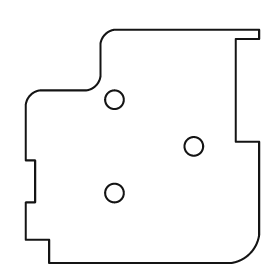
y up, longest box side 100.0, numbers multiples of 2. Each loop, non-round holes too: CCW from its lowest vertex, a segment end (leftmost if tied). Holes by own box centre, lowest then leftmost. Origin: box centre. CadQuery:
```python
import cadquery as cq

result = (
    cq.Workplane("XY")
    .moveTo(-40.0, -50.0)
    .lineTo(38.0, -50.0)
    .threePointArc((46.0, -46.0), (50.0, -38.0))
    .lineTo(50.0, 2.0)
    .lineTo(40.0, 2.0)
    .lineTo(40.0, 46.0)
    .lineTo(50.0, 46.0)
    .lineTo(50.0, 50.0)
    .lineTo(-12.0, 50.0)
    .threePointArc((-16.0, 48.0), (-18.0, 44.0))
    .lineTo(-18.0, 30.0)
    .threePointArc((-20.0, 26.0), (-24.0, 24.0))
    .lineTo(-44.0, 24.0)
    .threePointArc((-48.0, 22.0), (-50.0, 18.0))
    .lineTo(-50.0, -6.0)
    .lineTo(-46.0, -6.0)
    .lineTo(-46.0, -24.0)
    .lineTo(-50.0, -24.0)
    .lineTo(-50.0, -40.0)
    .lineTo(-40.0, -40.0)
    .close()
    .moveTo(-12.0, -20.0)
    .circle(4.0)
    .moveTo(22.0, 0.0)
    .circle(4.0)
    .moveTo(-12.0, 20.0)
    .circle(4.0)
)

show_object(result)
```